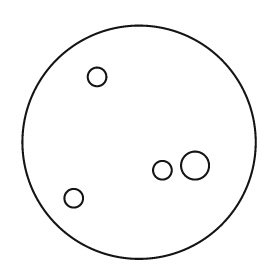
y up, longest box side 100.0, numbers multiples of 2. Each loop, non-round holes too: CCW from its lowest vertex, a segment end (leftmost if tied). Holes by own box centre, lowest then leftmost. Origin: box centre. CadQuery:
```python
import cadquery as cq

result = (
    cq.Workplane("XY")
    .moveTo(0.0, 0.0)
    .circle(50.0)
    .moveTo(-28.0, -24.0)
    .circle(4.0)
    .moveTo(10.0, -12.0)
    .circle(4.0)
    .moveTo(24.0, -10.0)
    .circle(6.0)
    .moveTo(-18.0, 28.0)
    .circle(4.0)
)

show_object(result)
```